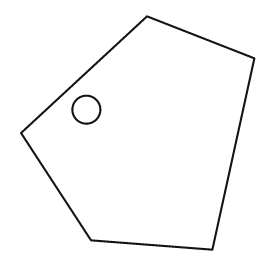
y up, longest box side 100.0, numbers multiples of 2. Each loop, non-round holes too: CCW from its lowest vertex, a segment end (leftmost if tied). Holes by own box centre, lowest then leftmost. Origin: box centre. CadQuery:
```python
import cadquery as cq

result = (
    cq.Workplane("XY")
    .moveTo(32.0, -50.0)
    .lineTo(50.0, 32.0)
    .lineTo(4.0, 50.0)
    .lineTo(-50.0, 0.0)
    .lineTo(-20.0, -46.0)
    .close()
    .moveTo(-22.0, 10.0)
    .circle(6.0)
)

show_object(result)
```